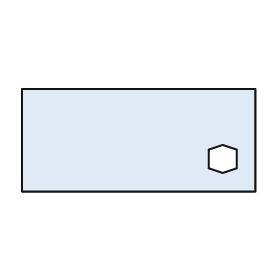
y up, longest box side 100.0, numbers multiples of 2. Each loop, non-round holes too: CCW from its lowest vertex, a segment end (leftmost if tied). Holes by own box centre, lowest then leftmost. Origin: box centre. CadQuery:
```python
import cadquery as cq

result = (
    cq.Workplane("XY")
    .moveTo(-50.0, -22.0)
    .lineTo(50.0, -22.0)
    .lineTo(50.0, 22.0)
    .lineTo(-50.0, 22.0)
    .close()
    .moveTo(36.0, -14.0)
    .lineTo(42.0, -12.0)
    .lineTo(42.0, -4.0)
    .lineTo(36.0, -2.0)
    .lineTo(30.0, -4.0)
    .lineTo(30.0, -12.0)
    .close()
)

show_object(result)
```